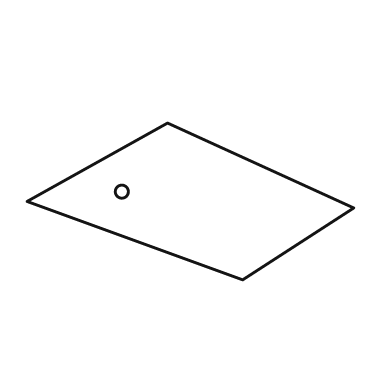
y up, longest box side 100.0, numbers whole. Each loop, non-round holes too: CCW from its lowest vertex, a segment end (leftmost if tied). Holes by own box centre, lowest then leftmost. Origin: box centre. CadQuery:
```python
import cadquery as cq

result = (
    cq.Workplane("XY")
    .moveTo(16.0, -24.0)
    .lineTo(50.0, -2.0)
    .lineTo(-7.0, 24.0)
    .lineTo(-50.0, 0.0)
    .close()
    .moveTo(-21.0, 3.0)
    .circle(2.0)
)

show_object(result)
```